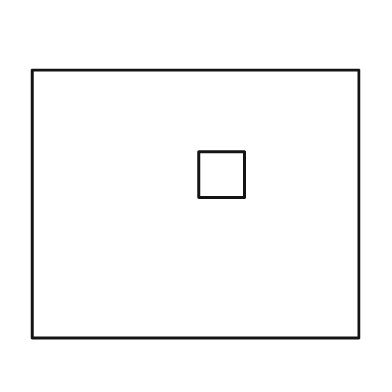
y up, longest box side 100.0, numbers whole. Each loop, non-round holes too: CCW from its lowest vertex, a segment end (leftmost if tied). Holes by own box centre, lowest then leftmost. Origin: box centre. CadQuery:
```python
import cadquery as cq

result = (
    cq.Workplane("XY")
    .moveTo(-50.0, -41.0)
    .lineTo(50.0, -41.0)
    .lineTo(50.0, 41.0)
    .lineTo(-50.0, 41.0)
    .close()
    .moveTo(1.0, 2.0)
    .lineTo(15.0, 2.0)
    .lineTo(15.0, 16.0)
    .lineTo(1.0, 16.0)
    .close()
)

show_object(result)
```